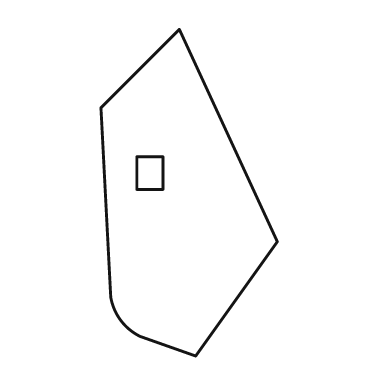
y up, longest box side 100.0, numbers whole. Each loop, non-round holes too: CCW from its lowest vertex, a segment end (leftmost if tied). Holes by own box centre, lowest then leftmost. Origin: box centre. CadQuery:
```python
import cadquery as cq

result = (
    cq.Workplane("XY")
    .moveTo(2.0, -50.0)
    .lineTo(27.0, -15.0)
    .lineTo(-3.0, 50.0)
    .lineTo(-27.0, 26.0)
    .lineTo(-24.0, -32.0)
    .threePointArc((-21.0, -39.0), (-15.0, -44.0))
    .close()
    .moveTo(-16.0, 1.0)
    .lineTo(-8.0, 1.0)
    .lineTo(-8.0, 11.0)
    .lineTo(-16.0, 11.0)
    .close()
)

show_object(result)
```